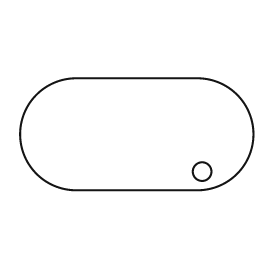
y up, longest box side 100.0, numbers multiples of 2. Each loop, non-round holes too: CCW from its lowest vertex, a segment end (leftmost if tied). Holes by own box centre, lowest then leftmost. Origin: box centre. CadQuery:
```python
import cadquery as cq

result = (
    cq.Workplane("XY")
    .moveTo(-26.0, -24.0)
    .lineTo(26.0, -24.0)
    .threePointArc((50.0, 0.0), (26.0, 24.0))
    .lineTo(-26.0, 24.0)
    .threePointArc((-50.0, 0.0), (-26.0, -24.0))
    .close()
    .moveTo(28.0, -16.0)
    .circle(4.0)
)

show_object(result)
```